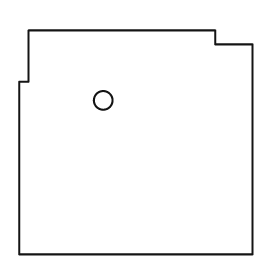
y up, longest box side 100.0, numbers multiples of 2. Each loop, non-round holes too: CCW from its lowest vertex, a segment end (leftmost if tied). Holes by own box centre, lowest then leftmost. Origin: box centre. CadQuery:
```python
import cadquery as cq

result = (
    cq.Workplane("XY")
    .moveTo(-50.0, -48.0)
    .lineTo(50.0, -48.0)
    .lineTo(50.0, 42.0)
    .lineTo(34.0, 42.0)
    .lineTo(34.0, 48.0)
    .lineTo(-46.0, 48.0)
    .lineTo(-46.0, 26.0)
    .lineTo(-50.0, 26.0)
    .close()
    .moveTo(-14.0, 18.0)
    .circle(4.0)
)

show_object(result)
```